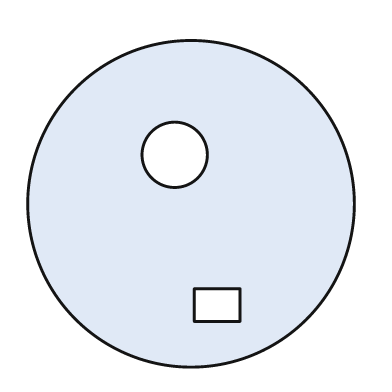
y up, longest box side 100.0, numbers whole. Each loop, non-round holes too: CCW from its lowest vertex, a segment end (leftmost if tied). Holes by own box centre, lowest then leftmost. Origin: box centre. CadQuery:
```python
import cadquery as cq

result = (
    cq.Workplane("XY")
    .moveTo(0.0, 0.0)
    .circle(50.0)
    .moveTo(1.0, -36.0)
    .lineTo(15.0, -36.0)
    .lineTo(15.0, -26.0)
    .lineTo(1.0, -26.0)
    .close()
    .moveTo(-5.0, 15.0)
    .circle(10.0)
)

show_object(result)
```